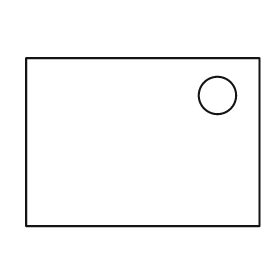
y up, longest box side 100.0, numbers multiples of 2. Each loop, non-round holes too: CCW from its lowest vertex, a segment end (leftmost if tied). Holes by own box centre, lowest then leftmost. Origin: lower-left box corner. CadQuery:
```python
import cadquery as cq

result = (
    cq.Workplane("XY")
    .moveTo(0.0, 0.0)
    .lineTo(100.0, 0.0)
    .lineTo(100.0, 72.0)
    .lineTo(0.0, 72.0)
    .close()
    .moveTo(82.0, 56.0)
    .circle(8.0)
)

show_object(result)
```